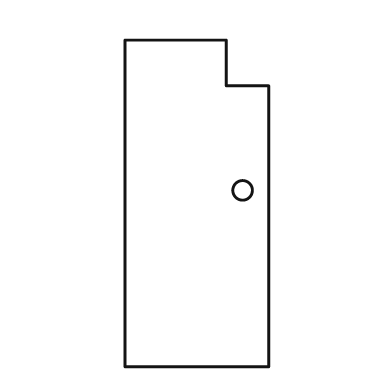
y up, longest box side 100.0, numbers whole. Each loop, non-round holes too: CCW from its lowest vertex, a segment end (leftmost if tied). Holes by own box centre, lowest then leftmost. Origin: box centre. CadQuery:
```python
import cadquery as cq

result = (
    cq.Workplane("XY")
    .moveTo(-22.0, -50.0)
    .lineTo(22.0, -50.0)
    .lineTo(22.0, 36.0)
    .lineTo(9.0, 36.0)
    .lineTo(9.0, 50.0)
    .lineTo(-22.0, 50.0)
    .close()
    .moveTo(14.0, 4.0)
    .circle(3.0)
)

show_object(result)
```